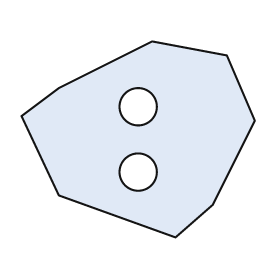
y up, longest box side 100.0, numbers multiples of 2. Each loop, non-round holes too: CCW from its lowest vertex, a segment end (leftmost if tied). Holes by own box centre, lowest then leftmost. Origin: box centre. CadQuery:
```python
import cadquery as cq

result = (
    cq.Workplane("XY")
    .moveTo(16.0, -42.0)
    .lineTo(32.0, -28.0)
    .lineTo(50.0, 8.0)
    .lineTo(38.0, 36.0)
    .lineTo(6.0, 42.0)
    .lineTo(-34.0, 22.0)
    .lineTo(-50.0, 10.0)
    .lineTo(-34.0, -24.0)
    .close()
    .moveTo(0.0, -14.0)
    .circle(8.0)
    .moveTo(0.0, 14.0)
    .circle(8.0)
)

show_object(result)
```